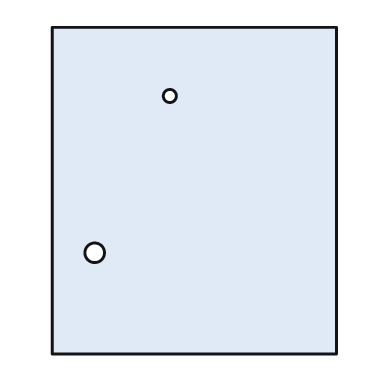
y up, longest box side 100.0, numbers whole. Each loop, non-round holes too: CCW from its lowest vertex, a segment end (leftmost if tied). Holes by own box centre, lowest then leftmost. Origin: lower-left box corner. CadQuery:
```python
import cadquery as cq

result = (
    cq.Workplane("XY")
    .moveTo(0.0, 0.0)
    .lineTo(87.0, 0.0)
    .lineTo(87.0, 100.0)
    .lineTo(0.0, 100.0)
    .close()
    .moveTo(13.0, 31.0)
    .circle(3.0)
    .moveTo(36.0, 79.0)
    .circle(2.0)
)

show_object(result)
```